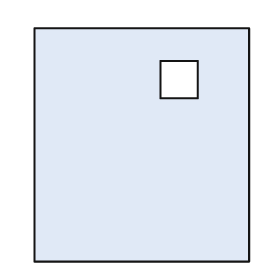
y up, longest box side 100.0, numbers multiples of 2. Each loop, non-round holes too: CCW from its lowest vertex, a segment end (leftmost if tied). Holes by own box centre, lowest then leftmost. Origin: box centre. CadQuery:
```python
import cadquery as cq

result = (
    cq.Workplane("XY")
    .moveTo(-46.0, -50.0)
    .lineTo(46.0, -50.0)
    .lineTo(46.0, 50.0)
    .lineTo(-46.0, 50.0)
    .close()
    .moveTo(8.0, 20.0)
    .lineTo(24.0, 20.0)
    .lineTo(24.0, 36.0)
    .lineTo(8.0, 36.0)
    .close()
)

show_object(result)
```